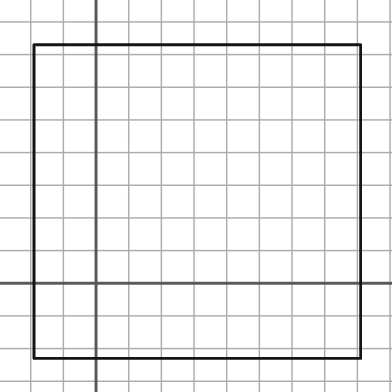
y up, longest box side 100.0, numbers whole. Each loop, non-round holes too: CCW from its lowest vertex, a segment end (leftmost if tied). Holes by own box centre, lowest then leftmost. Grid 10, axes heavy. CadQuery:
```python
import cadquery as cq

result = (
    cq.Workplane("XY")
    .moveTo(-19.0, -23.0)
    .lineTo(81.0, -23.0)
    .lineTo(81.0, 73.0)
    .lineTo(-19.0, 73.0)
    .close()
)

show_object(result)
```